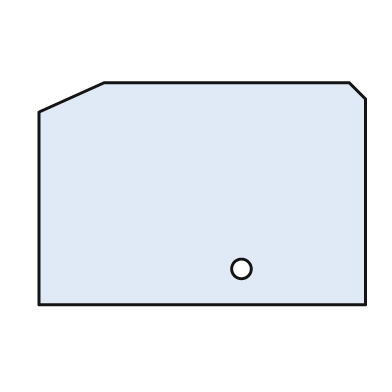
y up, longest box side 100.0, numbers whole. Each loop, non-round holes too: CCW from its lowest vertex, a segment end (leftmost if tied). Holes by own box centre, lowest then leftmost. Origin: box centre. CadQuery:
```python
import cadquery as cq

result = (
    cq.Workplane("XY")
    .moveTo(-50.0, -34.0)
    .lineTo(50.0, -34.0)
    .lineTo(50.0, 29.0)
    .lineTo(45.0, 34.0)
    .lineTo(-30.0, 34.0)
    .lineTo(-50.0, 25.0)
    .close()
    .moveTo(12.0, -23.0)
    .circle(3.0)
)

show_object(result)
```